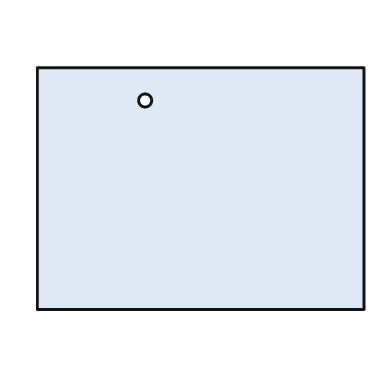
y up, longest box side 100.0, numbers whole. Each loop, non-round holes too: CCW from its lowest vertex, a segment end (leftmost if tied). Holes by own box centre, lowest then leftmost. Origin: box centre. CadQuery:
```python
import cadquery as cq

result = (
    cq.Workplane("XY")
    .moveTo(-50.0, -37.0)
    .lineTo(50.0, -37.0)
    .lineTo(50.0, 37.0)
    .lineTo(-50.0, 37.0)
    .close()
    .moveTo(-17.0, 27.0)
    .circle(2.0)
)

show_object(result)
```